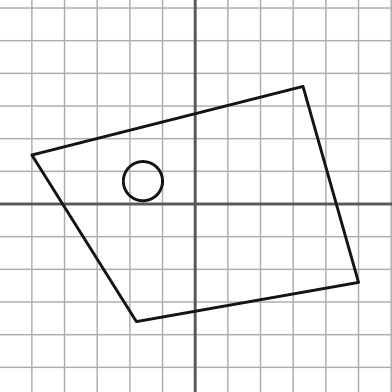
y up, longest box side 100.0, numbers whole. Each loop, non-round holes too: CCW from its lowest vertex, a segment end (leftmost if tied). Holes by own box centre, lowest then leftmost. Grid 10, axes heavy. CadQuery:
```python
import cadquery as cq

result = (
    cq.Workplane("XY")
    .moveTo(-18.0, -36.0)
    .lineTo(50.0, -24.0)
    .lineTo(33.0, 36.0)
    .lineTo(-50.0, 15.0)
    .close()
    .moveTo(-16.0, 7.0)
    .circle(6.0)
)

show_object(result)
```